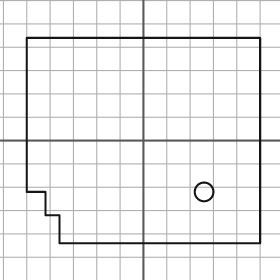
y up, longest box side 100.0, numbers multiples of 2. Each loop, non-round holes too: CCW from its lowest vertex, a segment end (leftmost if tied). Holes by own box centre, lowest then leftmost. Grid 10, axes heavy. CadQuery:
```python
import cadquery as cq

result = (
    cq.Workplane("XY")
    .moveTo(-36.0, -44.0)
    .lineTo(50.0, -44.0)
    .lineTo(50.0, 44.0)
    .lineTo(-50.0, 44.0)
    .lineTo(-50.0, -22.0)
    .lineTo(-42.0, -22.0)
    .lineTo(-42.0, -32.0)
    .lineTo(-36.0, -32.0)
    .close()
    .moveTo(26.0, -22.0)
    .circle(4.0)
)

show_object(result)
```